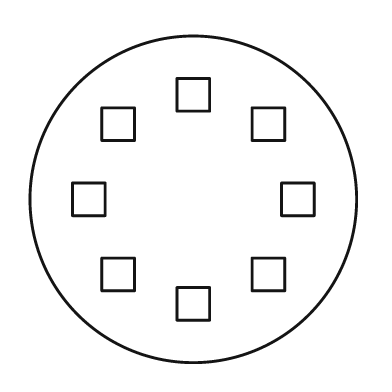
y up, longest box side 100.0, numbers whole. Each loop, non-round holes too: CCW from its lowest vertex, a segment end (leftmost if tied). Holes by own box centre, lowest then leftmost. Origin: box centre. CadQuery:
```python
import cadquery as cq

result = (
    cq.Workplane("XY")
    .moveTo(0.0, 0.0)
    .circle(50.0)
    .moveTo(-5.0, -37.0)
    .lineTo(5.0, -37.0)
    .lineTo(5.0, -27.0)
    .lineTo(-5.0, -27.0)
    .close()
    .moveTo(-28.0, -28.0)
    .lineTo(-18.0, -28.0)
    .lineTo(-18.0, -18.0)
    .lineTo(-28.0, -18.0)
    .close()
    .moveTo(18.0, -28.0)
    .lineTo(28.0, -28.0)
    .lineTo(28.0, -18.0)
    .lineTo(18.0, -18.0)
    .close()
    .moveTo(-37.0, -5.0)
    .lineTo(-27.0, -5.0)
    .lineTo(-27.0, 5.0)
    .lineTo(-37.0, 5.0)
    .close()
    .moveTo(27.0, -5.0)
    .lineTo(37.0, -5.0)
    .lineTo(37.0, 5.0)
    .lineTo(27.0, 5.0)
    .close()
    .moveTo(-28.0, 18.0)
    .lineTo(-18.0, 18.0)
    .lineTo(-18.0, 28.0)
    .lineTo(-28.0, 28.0)
    .close()
    .moveTo(18.0, 18.0)
    .lineTo(28.0, 18.0)
    .lineTo(28.0, 28.0)
    .lineTo(18.0, 28.0)
    .close()
    .moveTo(-5.0, 27.0)
    .lineTo(5.0, 27.0)
    .lineTo(5.0, 37.0)
    .lineTo(-5.0, 37.0)
    .close()
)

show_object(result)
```